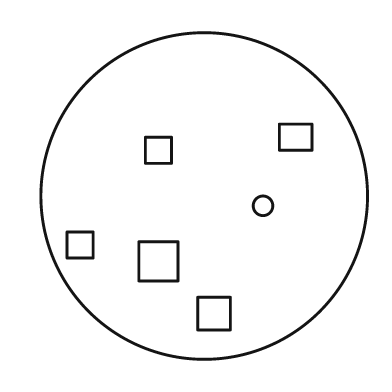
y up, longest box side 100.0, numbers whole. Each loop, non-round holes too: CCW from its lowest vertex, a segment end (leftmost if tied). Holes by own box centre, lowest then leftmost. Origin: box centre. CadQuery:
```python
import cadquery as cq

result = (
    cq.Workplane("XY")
    .moveTo(0.0, 0.0)
    .circle(50.0)
    .moveTo(-2.0, -41.0)
    .lineTo(8.0, -41.0)
    .lineTo(8.0, -31.0)
    .lineTo(-2.0, -31.0)
    .close()
    .moveTo(-20.0, -26.0)
    .lineTo(-8.0, -26.0)
    .lineTo(-8.0, -14.0)
    .lineTo(-20.0, -14.0)
    .close()
    .moveTo(-42.0, -19.0)
    .lineTo(-34.0, -19.0)
    .lineTo(-34.0, -11.0)
    .lineTo(-42.0, -11.0)
    .close()
    .moveTo(18.0, -3.0)
    .circle(3.0)
    .moveTo(-18.0, 10.0)
    .lineTo(-10.0, 10.0)
    .lineTo(-10.0, 18.0)
    .lineTo(-18.0, 18.0)
    .close()
    .moveTo(23.0, 14.0)
    .lineTo(33.0, 14.0)
    .lineTo(33.0, 22.0)
    .lineTo(23.0, 22.0)
    .close()
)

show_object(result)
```